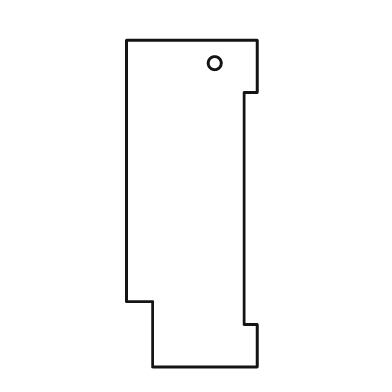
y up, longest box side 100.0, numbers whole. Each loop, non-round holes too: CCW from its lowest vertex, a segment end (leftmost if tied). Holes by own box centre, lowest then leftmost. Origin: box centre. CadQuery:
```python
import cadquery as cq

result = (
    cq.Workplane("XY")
    .moveTo(-12.0, -50.0)
    .lineTo(20.0, -50.0)
    .lineTo(20.0, -37.0)
    .lineTo(16.0, -37.0)
    .lineTo(16.0, 34.0)
    .lineTo(20.0, 34.0)
    .lineTo(20.0, 50.0)
    .lineTo(-20.0, 50.0)
    .lineTo(-20.0, -30.0)
    .lineTo(-12.0, -30.0)
    .close()
    .moveTo(7.0, 43.0)
    .circle(2.0)
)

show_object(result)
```